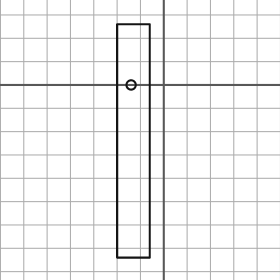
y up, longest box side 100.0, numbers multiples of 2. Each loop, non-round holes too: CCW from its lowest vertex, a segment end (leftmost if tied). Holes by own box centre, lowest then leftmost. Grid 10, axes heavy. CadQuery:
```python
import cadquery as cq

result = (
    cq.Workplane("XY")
    .moveTo(-20.0, -74.0)
    .lineTo(-6.0, -74.0)
    .lineTo(-6.0, 26.0)
    .lineTo(-20.0, 26.0)
    .close()
    .moveTo(-14.0, 0.0)
    .circle(2.0)
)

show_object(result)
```